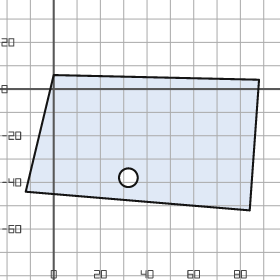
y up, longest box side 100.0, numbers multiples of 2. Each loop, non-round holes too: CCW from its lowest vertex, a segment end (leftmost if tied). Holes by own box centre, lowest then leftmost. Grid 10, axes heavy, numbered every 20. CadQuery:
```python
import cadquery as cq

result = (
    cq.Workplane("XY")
    .moveTo(84.0, -52.0)
    .lineTo(88.0, 4.0)
    .lineTo(0.0, 6.0)
    .lineTo(-12.0, -44.0)
    .close()
    .moveTo(32.0, -38.0)
    .circle(4.0)
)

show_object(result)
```